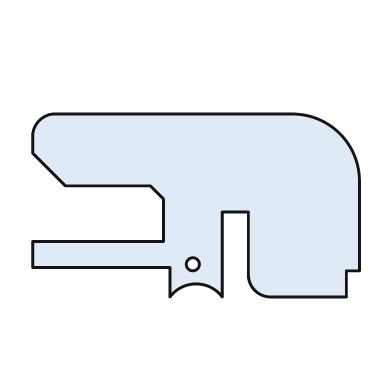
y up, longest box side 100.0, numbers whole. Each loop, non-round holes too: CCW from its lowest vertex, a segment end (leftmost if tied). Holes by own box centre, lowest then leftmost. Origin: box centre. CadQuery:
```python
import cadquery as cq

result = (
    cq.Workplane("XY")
    .moveTo(-8.0, -28.0)
    .threePointArc((0.0, -24.0), (8.0, -28.0))
    .lineTo(8.0, -2.0)
    .lineTo(16.0, -2.0)
    .lineTo(16.0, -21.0)
    .threePointArc((18.0, -26.0), (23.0, -28.0))
    .lineTo(46.0, -28.0)
    .lineTo(46.0, -20.0)
    .lineTo(50.0, -20.0)
    .lineTo(50.0, 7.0)
    .threePointArc((44.0, 22.0), (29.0, 28.0))
    .lineTo(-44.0, 28.0)
    .threePointArc((-48.0, 26.0), (-50.0, 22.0))
    .lineTo(-50.0, 16.0)
    .lineTo(-40.0, 6.0)
    .lineTo(-14.0, 6.0)
    .lineTo(-10.0, 2.0)
    .lineTo(-10.0, -11.0)
    .lineTo(-50.0, -11.0)
    .lineTo(-50.0, -19.0)
    .lineTo(-8.0, -19.0)
    .close()
    .moveTo(-1.0, -18.0)
    .circle(2.0)
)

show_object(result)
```